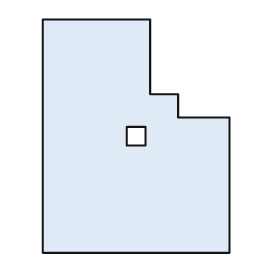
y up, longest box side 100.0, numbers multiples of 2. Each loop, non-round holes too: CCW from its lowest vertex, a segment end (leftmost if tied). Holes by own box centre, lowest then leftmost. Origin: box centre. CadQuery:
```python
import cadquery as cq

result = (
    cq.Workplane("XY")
    .moveTo(-40.0, -50.0)
    .lineTo(40.0, -50.0)
    .lineTo(40.0, 8.0)
    .lineTo(18.0, 8.0)
    .lineTo(18.0, 18.0)
    .lineTo(6.0, 18.0)
    .lineTo(6.0, 50.0)
    .lineTo(-40.0, 50.0)
    .close()
    .moveTo(-4.0, -4.0)
    .lineTo(4.0, -4.0)
    .lineTo(4.0, 4.0)
    .lineTo(-4.0, 4.0)
    .close()
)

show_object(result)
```